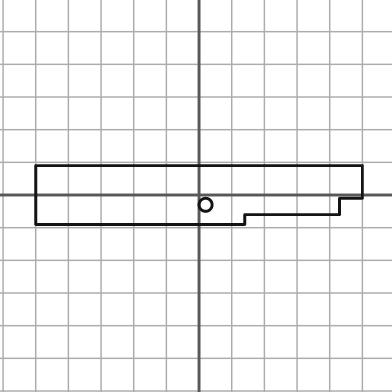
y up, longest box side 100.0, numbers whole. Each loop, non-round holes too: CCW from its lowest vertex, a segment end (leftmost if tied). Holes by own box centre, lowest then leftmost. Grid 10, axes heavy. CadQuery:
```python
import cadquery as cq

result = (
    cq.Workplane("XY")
    .moveTo(-50.0, -9.0)
    .lineTo(14.0, -9.0)
    .lineTo(14.0, -6.0)
    .lineTo(43.0, -6.0)
    .lineTo(43.0, -1.0)
    .lineTo(50.0, -1.0)
    .lineTo(50.0, 9.0)
    .lineTo(-50.0, 9.0)
    .close()
    .moveTo(2.0, -3.0)
    .circle(2.0)
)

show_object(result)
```